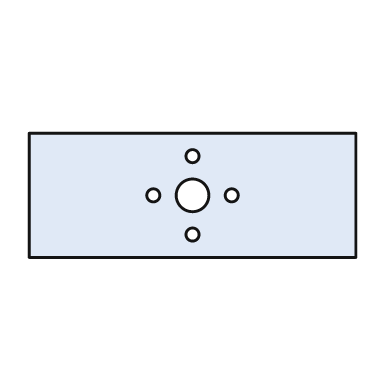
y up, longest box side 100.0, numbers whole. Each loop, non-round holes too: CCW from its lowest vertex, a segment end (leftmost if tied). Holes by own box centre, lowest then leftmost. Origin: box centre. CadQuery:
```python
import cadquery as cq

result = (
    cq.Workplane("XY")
    .moveTo(-50.0, -19.0)
    .lineTo(50.0, -19.0)
    .lineTo(50.0, 19.0)
    .lineTo(-50.0, 19.0)
    .close()
    .moveTo(0.0, -12.0)
    .circle(2.0)
    .moveTo(-12.0, 0.0)
    .circle(2.0)
    .moveTo(0.0, 0.0)
    .circle(5.0)
    .moveTo(12.0, 0.0)
    .circle(2.0)
    .moveTo(0.0, 12.0)
    .circle(2.0)
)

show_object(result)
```